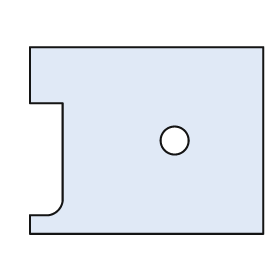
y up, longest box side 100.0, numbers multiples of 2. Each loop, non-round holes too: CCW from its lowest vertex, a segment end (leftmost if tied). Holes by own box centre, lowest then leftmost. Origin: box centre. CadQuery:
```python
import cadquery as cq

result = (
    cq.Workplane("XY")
    .moveTo(-50.0, -40.0)
    .lineTo(50.0, -40.0)
    .lineTo(50.0, 40.0)
    .lineTo(-50.0, 40.0)
    .lineTo(-50.0, 16.0)
    .lineTo(-36.0, 16.0)
    .lineTo(-36.0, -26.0)
    .threePointArc((-38.0, -30.0), (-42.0, -32.0))
    .lineTo(-50.0, -32.0)
    .close()
    .moveTo(12.0, 0.0)
    .circle(6.0)
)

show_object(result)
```